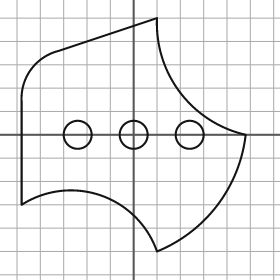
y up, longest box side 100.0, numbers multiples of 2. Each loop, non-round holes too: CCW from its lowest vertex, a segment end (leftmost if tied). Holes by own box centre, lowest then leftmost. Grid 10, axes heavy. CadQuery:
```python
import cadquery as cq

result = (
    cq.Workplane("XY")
    .moveTo(10.0, -50.0)
    .threePointArc((36.0, -30.0), (48.0, 0.0))
    .threePointArc((20.0, 18.0), (10.0, 50.0))
    .lineTo(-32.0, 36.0)
    .threePointArc((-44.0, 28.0), (-48.0, 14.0))
    .lineTo(-48.0, -30.0)
    .threePointArc((-14.0, -26.0), (10.0, -50.0))
    .close()
    .moveTo(-24.0, 0.0)
    .circle(6.0)
    .moveTo(0.0, 0.0)
    .circle(6.0)
    .moveTo(24.0, 0.0)
    .circle(6.0)
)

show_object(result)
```